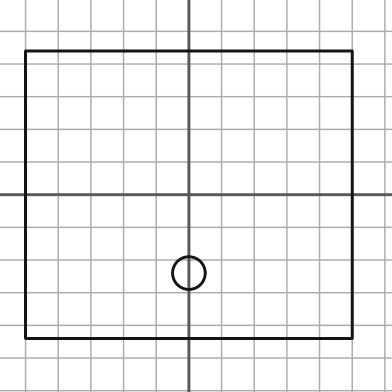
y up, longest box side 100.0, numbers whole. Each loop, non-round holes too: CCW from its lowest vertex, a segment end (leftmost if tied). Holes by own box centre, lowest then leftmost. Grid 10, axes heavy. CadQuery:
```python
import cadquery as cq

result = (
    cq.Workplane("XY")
    .moveTo(-50.0, -44.0)
    .lineTo(50.0, -44.0)
    .lineTo(50.0, 44.0)
    .lineTo(-50.0, 44.0)
    .close()
    .moveTo(0.0, -24.0)
    .circle(5.0)
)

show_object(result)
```